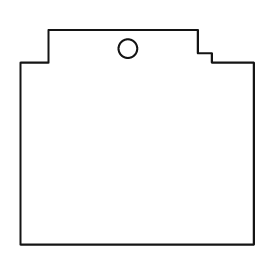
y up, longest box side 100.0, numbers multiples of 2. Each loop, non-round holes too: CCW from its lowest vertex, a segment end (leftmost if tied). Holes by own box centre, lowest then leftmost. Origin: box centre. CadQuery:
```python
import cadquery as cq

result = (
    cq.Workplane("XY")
    .moveTo(-50.0, -46.0)
    .lineTo(50.0, -46.0)
    .lineTo(50.0, 32.0)
    .lineTo(32.0, 32.0)
    .lineTo(32.0, 36.0)
    .lineTo(26.0, 36.0)
    .lineTo(26.0, 46.0)
    .lineTo(-38.0, 46.0)
    .lineTo(-38.0, 32.0)
    .lineTo(-50.0, 32.0)
    .close()
    .moveTo(-4.0, 38.0)
    .circle(4.0)
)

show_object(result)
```